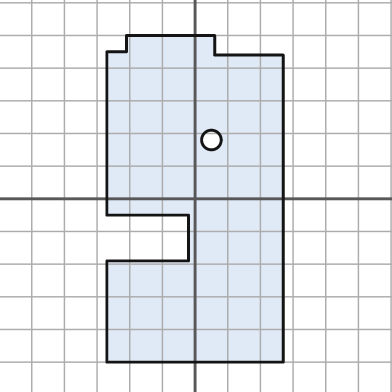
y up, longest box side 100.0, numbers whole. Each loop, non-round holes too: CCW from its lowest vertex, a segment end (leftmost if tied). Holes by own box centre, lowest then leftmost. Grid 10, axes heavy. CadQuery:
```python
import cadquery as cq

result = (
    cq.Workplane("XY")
    .moveTo(-27.0, -50.0)
    .lineTo(27.0, -50.0)
    .lineTo(27.0, 44.0)
    .lineTo(6.0, 44.0)
    .lineTo(6.0, 50.0)
    .lineTo(-21.0, 50.0)
    .lineTo(-21.0, 45.0)
    .lineTo(-27.0, 45.0)
    .lineTo(-27.0, -5.0)
    .lineTo(-2.0, -5.0)
    .lineTo(-2.0, -19.0)
    .lineTo(-27.0, -19.0)
    .close()
    .moveTo(5.0, 18.0)
    .circle(3.0)
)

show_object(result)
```